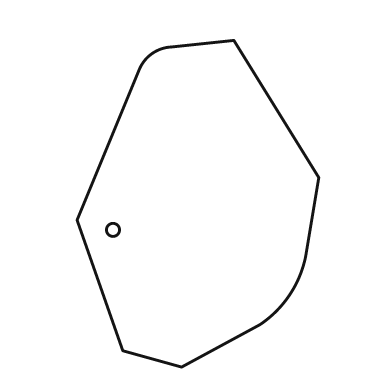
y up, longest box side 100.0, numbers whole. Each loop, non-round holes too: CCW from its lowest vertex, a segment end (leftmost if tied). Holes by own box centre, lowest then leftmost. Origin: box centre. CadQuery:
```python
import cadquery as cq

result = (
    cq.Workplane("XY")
    .moveTo(-5.0, -50.0)
    .lineTo(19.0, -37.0)
    .threePointArc((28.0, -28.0), (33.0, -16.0))
    .lineTo(37.0, 8.0)
    .lineTo(11.0, 50.0)
    .lineTo(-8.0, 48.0)
    .threePointArc((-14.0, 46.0), (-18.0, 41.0))
    .lineTo(-37.0, -5.0)
    .lineTo(-23.0, -45.0)
    .close()
    .moveTo(-26.0, -8.0)
    .circle(2.0)
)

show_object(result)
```